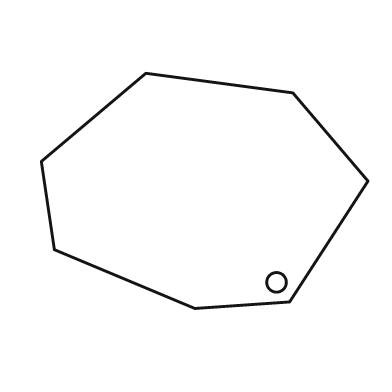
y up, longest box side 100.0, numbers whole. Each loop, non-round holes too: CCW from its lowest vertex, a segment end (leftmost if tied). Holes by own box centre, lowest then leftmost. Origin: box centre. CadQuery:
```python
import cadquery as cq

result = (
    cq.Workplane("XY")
    .moveTo(-3.0, -36.0)
    .lineTo(26.0, -34.0)
    .lineTo(50.0, 3.0)
    .lineTo(27.0, 30.0)
    .lineTo(-18.0, 36.0)
    .lineTo(-50.0, 9.0)
    .lineTo(-46.0, -18.0)
    .close()
    .moveTo(22.0, -28.0)
    .circle(3.0)
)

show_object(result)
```